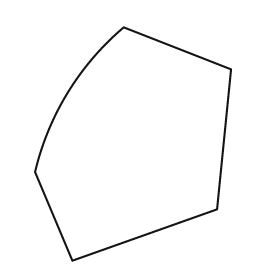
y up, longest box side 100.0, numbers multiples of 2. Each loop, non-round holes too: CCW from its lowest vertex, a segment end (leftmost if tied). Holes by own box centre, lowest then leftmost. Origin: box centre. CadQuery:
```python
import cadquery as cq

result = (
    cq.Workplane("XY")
    .moveTo(-26.0, -50.0)
    .lineTo(36.0, -28.0)
    .lineTo(42.0, 32.0)
    .lineTo(-4.0, 50.0)
    .threePointArc((-28.0, 22.0), (-42.0, -12.0))
    .close()
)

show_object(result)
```